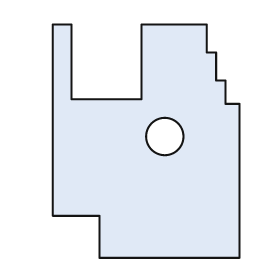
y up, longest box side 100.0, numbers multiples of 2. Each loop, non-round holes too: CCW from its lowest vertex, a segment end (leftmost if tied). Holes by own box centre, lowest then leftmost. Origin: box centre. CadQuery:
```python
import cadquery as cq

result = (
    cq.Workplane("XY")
    .moveTo(-20.0, -50.0)
    .lineTo(40.0, -50.0)
    .lineTo(40.0, 16.0)
    .lineTo(34.0, 16.0)
    .lineTo(34.0, 26.0)
    .lineTo(30.0, 26.0)
    .lineTo(30.0, 38.0)
    .lineTo(26.0, 38.0)
    .lineTo(26.0, 50.0)
    .lineTo(-2.0, 50.0)
    .lineTo(-2.0, 18.0)
    .lineTo(-32.0, 18.0)
    .lineTo(-32.0, 50.0)
    .lineTo(-40.0, 50.0)
    .lineTo(-40.0, -32.0)
    .lineTo(-20.0, -32.0)
    .close()
    .moveTo(8.0, 2.0)
    .circle(8.0)
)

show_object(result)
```